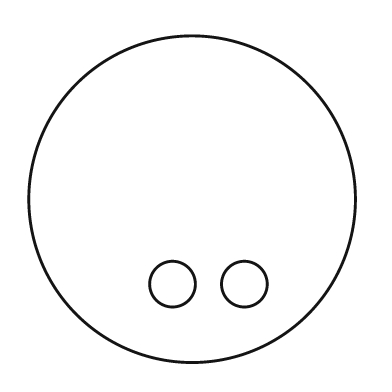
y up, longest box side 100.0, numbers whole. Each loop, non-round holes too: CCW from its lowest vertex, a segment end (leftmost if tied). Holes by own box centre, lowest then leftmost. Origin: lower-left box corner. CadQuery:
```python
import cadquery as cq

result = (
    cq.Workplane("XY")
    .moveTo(50.0, 50.0)
    .circle(50.0)
    .moveTo(44.0, 24.0)
    .circle(7.0)
    .moveTo(66.0, 24.0)
    .circle(7.0)
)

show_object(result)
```